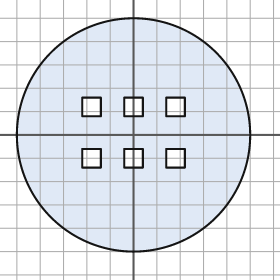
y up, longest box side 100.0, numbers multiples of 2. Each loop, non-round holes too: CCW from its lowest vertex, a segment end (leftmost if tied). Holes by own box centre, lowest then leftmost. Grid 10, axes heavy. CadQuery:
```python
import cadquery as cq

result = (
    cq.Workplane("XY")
    .moveTo(0.0, 0.0)
    .circle(50.0)
    .moveTo(-22.0, -14.0)
    .lineTo(-14.0, -14.0)
    .lineTo(-14.0, -6.0)
    .lineTo(-22.0, -6.0)
    .close()
    .moveTo(-4.0, -14.0)
    .lineTo(4.0, -14.0)
    .lineTo(4.0, -6.0)
    .lineTo(-4.0, -6.0)
    .close()
    .moveTo(14.0, -14.0)
    .lineTo(22.0, -14.0)
    .lineTo(22.0, -6.0)
    .lineTo(14.0, -6.0)
    .close()
    .moveTo(-22.0, 8.0)
    .lineTo(-14.0, 8.0)
    .lineTo(-14.0, 16.0)
    .lineTo(-22.0, 16.0)
    .close()
    .moveTo(-4.0, 8.0)
    .lineTo(4.0, 8.0)
    .lineTo(4.0, 16.0)
    .lineTo(-4.0, 16.0)
    .close()
    .moveTo(14.0, 8.0)
    .lineTo(22.0, 8.0)
    .lineTo(22.0, 16.0)
    .lineTo(14.0, 16.0)
    .close()
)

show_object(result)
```